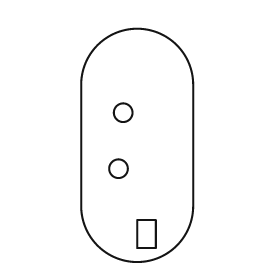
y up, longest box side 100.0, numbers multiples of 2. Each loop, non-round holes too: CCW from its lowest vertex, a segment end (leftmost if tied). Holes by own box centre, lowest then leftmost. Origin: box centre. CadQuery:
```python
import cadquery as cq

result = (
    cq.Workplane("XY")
    .moveTo(-24.0, -26.0)
    .threePointArc((0.0, -50.0), (24.0, -26.0))
    .lineTo(24.0, 26.0)
    .threePointArc((0.0, 50.0), (-24.0, 26.0))
    .close()
    .moveTo(0.0, -44.0)
    .lineTo(8.0, -44.0)
    .lineTo(8.0, -32.0)
    .lineTo(0.0, -32.0)
    .close()
    .moveTo(-8.0, -10.0)
    .circle(4.0)
    .moveTo(-6.0, 14.0)
    .circle(4.0)
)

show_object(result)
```